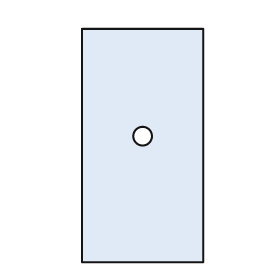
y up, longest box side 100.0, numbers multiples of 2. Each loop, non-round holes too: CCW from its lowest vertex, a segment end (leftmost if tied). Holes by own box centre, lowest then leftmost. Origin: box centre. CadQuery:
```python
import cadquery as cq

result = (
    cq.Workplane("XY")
    .moveTo(-26.0, -50.0)
    .lineTo(26.0, -50.0)
    .lineTo(26.0, 50.0)
    .lineTo(-26.0, 50.0)
    .close()
    .moveTo(0.0, 4.0)
    .circle(4.0)
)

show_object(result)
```